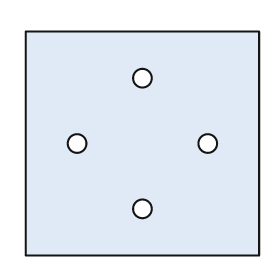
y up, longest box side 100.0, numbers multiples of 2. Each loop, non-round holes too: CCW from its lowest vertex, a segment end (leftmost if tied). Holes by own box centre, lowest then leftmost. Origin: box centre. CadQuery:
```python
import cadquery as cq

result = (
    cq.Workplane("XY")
    .moveTo(-50.0, -48.0)
    .lineTo(50.0, -48.0)
    .lineTo(50.0, 48.0)
    .lineTo(-50.0, 48.0)
    .close()
    .moveTo(0.0, -28.0)
    .circle(4.0)
    .moveTo(-28.0, 0.0)
    .circle(4.0)
    .moveTo(28.0, 0.0)
    .circle(4.0)
    .moveTo(0.0, 28.0)
    .circle(4.0)
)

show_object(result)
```